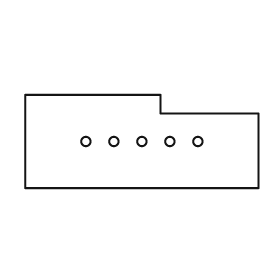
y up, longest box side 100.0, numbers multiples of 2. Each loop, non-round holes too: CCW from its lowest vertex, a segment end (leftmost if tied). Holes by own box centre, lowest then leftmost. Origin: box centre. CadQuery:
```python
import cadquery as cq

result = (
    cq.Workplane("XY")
    .moveTo(-50.0, -20.0)
    .lineTo(50.0, -20.0)
    .lineTo(50.0, 12.0)
    .lineTo(8.0, 12.0)
    .lineTo(8.0, 20.0)
    .lineTo(-50.0, 20.0)
    .close()
    .moveTo(-24.0, 0.0)
    .circle(2.0)
    .moveTo(-12.0, 0.0)
    .circle(2.0)
    .moveTo(0.0, 0.0)
    .circle(2.0)
    .moveTo(12.0, 0.0)
    .circle(2.0)
    .moveTo(24.0, 0.0)
    .circle(2.0)
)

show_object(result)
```